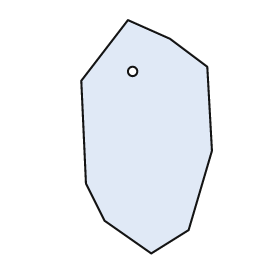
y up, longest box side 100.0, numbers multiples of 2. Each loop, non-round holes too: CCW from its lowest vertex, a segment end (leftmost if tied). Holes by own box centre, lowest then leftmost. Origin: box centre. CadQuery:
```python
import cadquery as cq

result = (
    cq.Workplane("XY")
    .moveTo(2.0, -50.0)
    .lineTo(18.0, -40.0)
    .lineTo(28.0, -6.0)
    .lineTo(26.0, 30.0)
    .lineTo(10.0, 42.0)
    .lineTo(-8.0, 50.0)
    .lineTo(-28.0, 24.0)
    .lineTo(-26.0, -20.0)
    .lineTo(-18.0, -36.0)
    .close()
    .moveTo(-6.0, 28.0)
    .circle(2.0)
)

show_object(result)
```